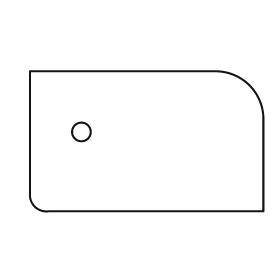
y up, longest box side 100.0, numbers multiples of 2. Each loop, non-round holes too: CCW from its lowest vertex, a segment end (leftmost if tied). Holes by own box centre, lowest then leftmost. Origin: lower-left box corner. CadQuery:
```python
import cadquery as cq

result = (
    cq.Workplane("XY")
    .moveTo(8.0, 0.0)
    .lineTo(100.0, 0.0)
    .lineTo(100.0, 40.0)
    .threePointArc((94.0, 54.0), (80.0, 60.0))
    .lineTo(0.0, 60.0)
    .lineTo(0.0, 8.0)
    .threePointArc((2.0, 2.0), (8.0, 0.0))
    .close()
    .moveTo(22.0, 34.0)
    .circle(4.0)
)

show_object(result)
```